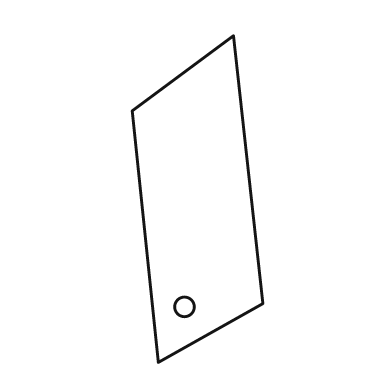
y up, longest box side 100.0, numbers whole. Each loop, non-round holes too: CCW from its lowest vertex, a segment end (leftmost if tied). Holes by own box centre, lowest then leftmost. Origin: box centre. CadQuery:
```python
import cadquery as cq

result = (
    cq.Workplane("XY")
    .moveTo(-12.0, -50.0)
    .lineTo(20.0, -32.0)
    .lineTo(11.0, 50.0)
    .lineTo(-20.0, 27.0)
    .close()
    .moveTo(-4.0, -33.0)
    .circle(3.0)
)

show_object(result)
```